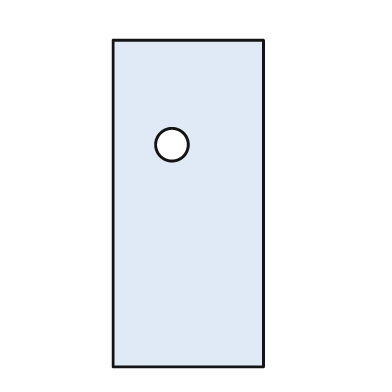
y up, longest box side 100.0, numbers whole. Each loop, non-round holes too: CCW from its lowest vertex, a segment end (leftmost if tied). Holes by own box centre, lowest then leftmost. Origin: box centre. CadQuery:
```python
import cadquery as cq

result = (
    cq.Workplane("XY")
    .moveTo(-23.0, -50.0)
    .lineTo(23.0, -50.0)
    .lineTo(23.0, 50.0)
    .lineTo(-23.0, 50.0)
    .close()
    .moveTo(-5.0, 18.0)
    .circle(5.0)
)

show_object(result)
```